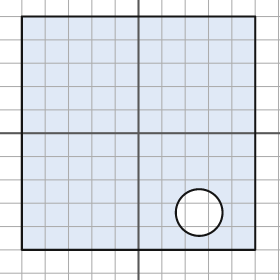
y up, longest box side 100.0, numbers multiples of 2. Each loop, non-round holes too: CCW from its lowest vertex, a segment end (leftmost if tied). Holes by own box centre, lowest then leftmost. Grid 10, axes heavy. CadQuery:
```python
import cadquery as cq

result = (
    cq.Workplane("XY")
    .moveTo(-50.0, -50.0)
    .lineTo(50.0, -50.0)
    .lineTo(50.0, 50.0)
    .lineTo(-50.0, 50.0)
    .close()
    .moveTo(26.0, -34.0)
    .circle(10.0)
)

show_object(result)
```